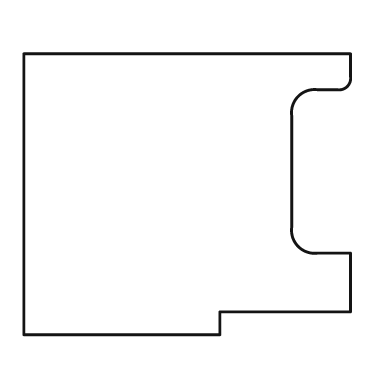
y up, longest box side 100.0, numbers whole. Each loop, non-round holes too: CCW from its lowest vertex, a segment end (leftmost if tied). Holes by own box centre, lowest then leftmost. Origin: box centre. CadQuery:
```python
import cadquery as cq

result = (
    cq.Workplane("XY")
    .moveTo(-50.0, -43.0)
    .lineTo(10.0, -43.0)
    .lineTo(10.0, -36.0)
    .lineTo(50.0, -36.0)
    .lineTo(50.0, -18.0)
    .lineTo(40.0, -18.0)
    .threePointArc((34.0, -16.0), (32.0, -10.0))
    .lineTo(32.0, 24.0)
    .threePointArc((34.0, 30.0), (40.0, 32.0))
    .lineTo(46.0, 32.0)
    .threePointArc((49.0, 33.0), (50.0, 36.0))
    .lineTo(50.0, 43.0)
    .lineTo(-50.0, 43.0)
    .close()
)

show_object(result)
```